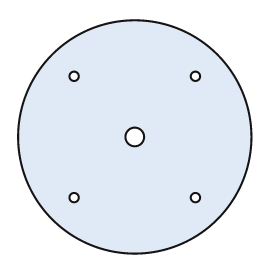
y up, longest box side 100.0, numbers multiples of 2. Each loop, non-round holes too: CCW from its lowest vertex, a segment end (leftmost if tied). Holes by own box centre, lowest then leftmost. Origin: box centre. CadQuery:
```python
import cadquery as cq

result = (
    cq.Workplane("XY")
    .moveTo(0.0, 0.0)
    .circle(50.0)
    .moveTo(-26.0, -26.0)
    .circle(2.0)
    .moveTo(26.0, -26.0)
    .circle(2.0)
    .moveTo(0.0, 0.0)
    .circle(4.0)
    .moveTo(-26.0, 26.0)
    .circle(2.0)
    .moveTo(26.0, 26.0)
    .circle(2.0)
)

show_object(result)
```